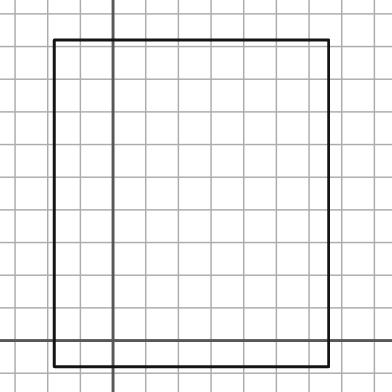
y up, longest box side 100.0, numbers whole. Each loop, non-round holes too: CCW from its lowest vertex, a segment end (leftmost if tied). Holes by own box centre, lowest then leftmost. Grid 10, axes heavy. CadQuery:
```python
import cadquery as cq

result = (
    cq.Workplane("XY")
    .moveTo(-18.0, -8.0)
    .lineTo(66.0, -8.0)
    .lineTo(66.0, 92.0)
    .lineTo(-18.0, 92.0)
    .close()
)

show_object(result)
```